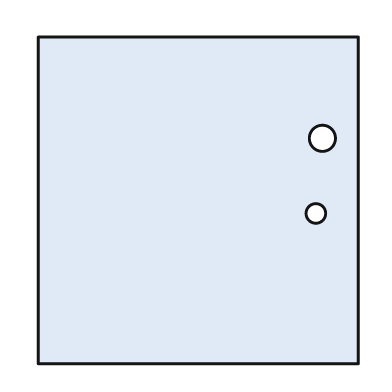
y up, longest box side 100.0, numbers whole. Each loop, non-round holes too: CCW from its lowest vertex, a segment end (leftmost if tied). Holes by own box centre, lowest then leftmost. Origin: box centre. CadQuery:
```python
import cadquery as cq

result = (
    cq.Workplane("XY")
    .moveTo(-49.0, -50.0)
    .lineTo(49.0, -50.0)
    .lineTo(49.0, 50.0)
    .lineTo(-49.0, 50.0)
    .close()
    .moveTo(36.0, -4.0)
    .circle(3.0)
    .moveTo(38.0, 19.0)
    .circle(4.0)
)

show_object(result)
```